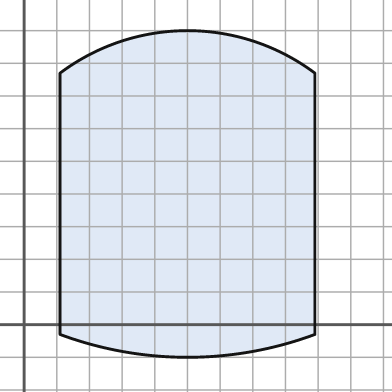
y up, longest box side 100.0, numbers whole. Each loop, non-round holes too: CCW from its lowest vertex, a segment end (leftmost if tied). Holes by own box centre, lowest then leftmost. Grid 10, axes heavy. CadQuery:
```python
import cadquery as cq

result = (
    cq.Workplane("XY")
    .moveTo(11.0, -3.0)
    .threePointArc((50.0, -10.0), (89.0, -3.0))
    .lineTo(89.0, 77.0)
    .threePointArc((50.0, 90.0), (11.0, 77.0))
    .close()
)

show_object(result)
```